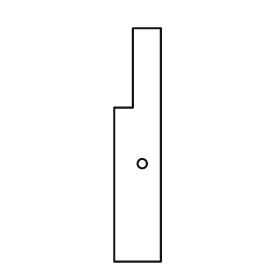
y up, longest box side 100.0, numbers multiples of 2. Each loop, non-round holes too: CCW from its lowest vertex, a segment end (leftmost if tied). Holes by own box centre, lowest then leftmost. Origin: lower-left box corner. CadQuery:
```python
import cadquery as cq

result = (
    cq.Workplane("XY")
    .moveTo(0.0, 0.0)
    .lineTo(20.0, 0.0)
    .lineTo(20.0, 100.0)
    .lineTo(8.0, 100.0)
    .lineTo(8.0, 66.0)
    .lineTo(0.0, 66.0)
    .close()
    .moveTo(12.0, 42.0)
    .circle(2.0)
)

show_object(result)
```